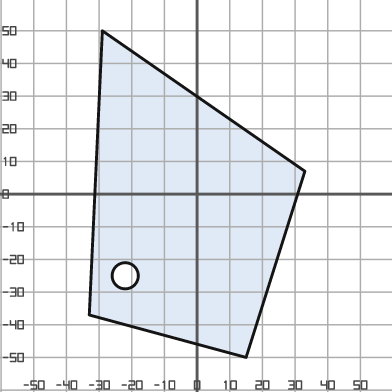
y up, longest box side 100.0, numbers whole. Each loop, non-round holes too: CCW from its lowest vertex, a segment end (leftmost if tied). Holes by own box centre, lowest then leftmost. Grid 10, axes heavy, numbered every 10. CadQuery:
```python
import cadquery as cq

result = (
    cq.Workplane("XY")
    .moveTo(15.0, -50.0)
    .lineTo(33.0, 7.0)
    .lineTo(-29.0, 50.0)
    .lineTo(-33.0, -37.0)
    .close()
    .moveTo(-22.0, -25.0)
    .circle(4.0)
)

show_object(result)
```